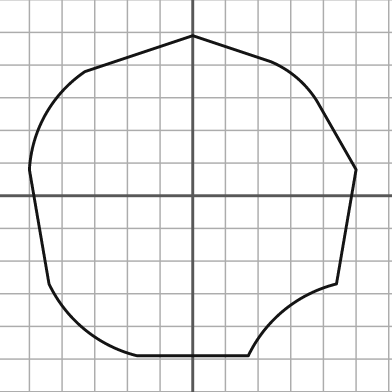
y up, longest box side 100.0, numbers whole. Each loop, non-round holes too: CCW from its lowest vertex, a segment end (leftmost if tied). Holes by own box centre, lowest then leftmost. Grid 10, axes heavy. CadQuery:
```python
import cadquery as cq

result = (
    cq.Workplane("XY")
    .moveTo(-17.0, -49.0)
    .lineTo(17.0, -49.0)
    .threePointArc((28.0, -35.0), (44.0, -27.0))
    .lineTo(50.0, 8.0)
    .lineTo(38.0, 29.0)
    .threePointArc((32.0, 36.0), (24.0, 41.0))
    .lineTo(0.0, 49.0)
    .lineTo(-33.0, 38.0)
    .threePointArc((-45.0, 25.0), (-50.0, 8.0))
    .lineTo(-44.0, -27.0)
    .threePointArc((-33.0, -41.0), (-17.0, -49.0))
    .close()
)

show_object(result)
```